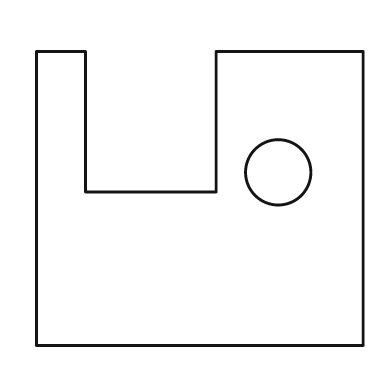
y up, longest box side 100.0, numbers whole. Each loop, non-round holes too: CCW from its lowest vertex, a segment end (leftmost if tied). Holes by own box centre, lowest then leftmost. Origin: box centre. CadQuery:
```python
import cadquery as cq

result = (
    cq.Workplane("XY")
    .moveTo(-50.0, -45.0)
    .lineTo(50.0, -45.0)
    .lineTo(50.0, 45.0)
    .lineTo(5.0, 45.0)
    .lineTo(5.0, 2.0)
    .lineTo(-35.0, 2.0)
    .lineTo(-35.0, 45.0)
    .lineTo(-50.0, 45.0)
    .close()
    .moveTo(24.0, 8.0)
    .circle(10.0)
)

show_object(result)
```